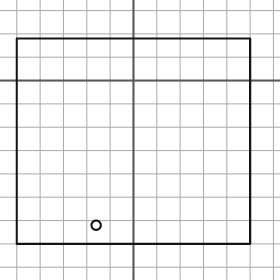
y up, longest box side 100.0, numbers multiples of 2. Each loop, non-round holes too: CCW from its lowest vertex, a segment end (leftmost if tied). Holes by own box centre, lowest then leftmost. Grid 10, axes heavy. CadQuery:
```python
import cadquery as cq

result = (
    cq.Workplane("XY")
    .moveTo(-50.0, -70.0)
    .lineTo(50.0, -70.0)
    .lineTo(50.0, 18.0)
    .lineTo(-50.0, 18.0)
    .close()
    .moveTo(-16.0, -62.0)
    .circle(2.0)
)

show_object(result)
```